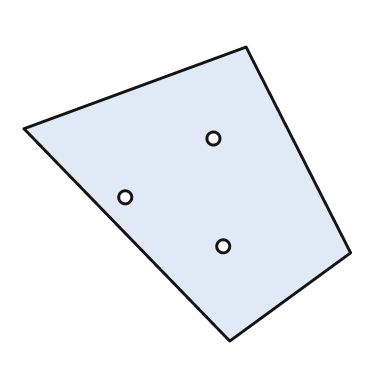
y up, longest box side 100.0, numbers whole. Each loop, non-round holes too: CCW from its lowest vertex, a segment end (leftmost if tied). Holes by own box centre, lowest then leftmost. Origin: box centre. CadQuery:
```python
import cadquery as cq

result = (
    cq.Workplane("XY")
    .moveTo(13.0, -45.0)
    .lineTo(50.0, -18.0)
    .lineTo(18.0, 45.0)
    .lineTo(-50.0, 20.0)
    .close()
    .moveTo(11.0, -16.0)
    .circle(2.0)
    .moveTo(-19.0, -1.0)
    .circle(2.0)
    .moveTo(8.0, 17.0)
    .circle(2.0)
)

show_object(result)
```